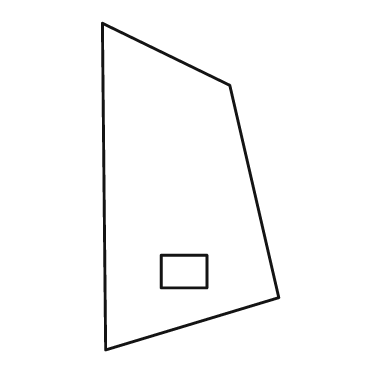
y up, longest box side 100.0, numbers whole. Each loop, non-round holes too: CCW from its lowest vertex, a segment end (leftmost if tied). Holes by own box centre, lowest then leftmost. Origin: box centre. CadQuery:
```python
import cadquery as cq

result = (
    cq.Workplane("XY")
    .moveTo(-26.0, -50.0)
    .lineTo(27.0, -34.0)
    .lineTo(12.0, 31.0)
    .lineTo(-27.0, 50.0)
    .close()
    .moveTo(-9.0, -31.0)
    .lineTo(5.0, -31.0)
    .lineTo(5.0, -21.0)
    .lineTo(-9.0, -21.0)
    .close()
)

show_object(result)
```